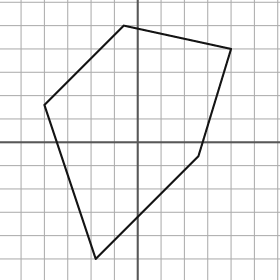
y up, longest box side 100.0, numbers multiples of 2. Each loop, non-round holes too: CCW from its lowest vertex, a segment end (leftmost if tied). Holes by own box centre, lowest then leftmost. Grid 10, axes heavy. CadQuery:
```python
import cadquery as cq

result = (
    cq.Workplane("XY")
    .moveTo(-18.0, -50.0)
    .lineTo(26.0, -6.0)
    .lineTo(40.0, 40.0)
    .lineTo(-6.0, 50.0)
    .lineTo(-40.0, 16.0)
    .close()
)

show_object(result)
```